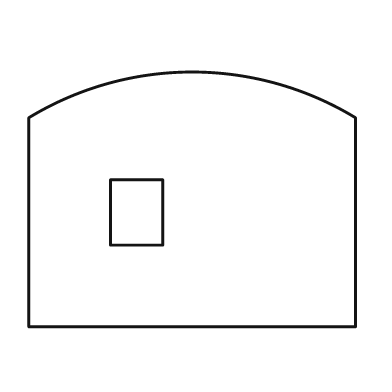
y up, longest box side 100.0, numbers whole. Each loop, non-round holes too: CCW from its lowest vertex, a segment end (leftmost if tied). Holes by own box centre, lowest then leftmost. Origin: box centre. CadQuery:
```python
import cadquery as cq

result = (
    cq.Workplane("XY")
    .moveTo(-50.0, -39.0)
    .lineTo(50.0, -39.0)
    .lineTo(50.0, 25.0)
    .threePointArc((0.0, 39.0), (-50.0, 25.0))
    .close()
    .moveTo(-25.0, -14.0)
    .lineTo(-9.0, -14.0)
    .lineTo(-9.0, 6.0)
    .lineTo(-25.0, 6.0)
    .close()
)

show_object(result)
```